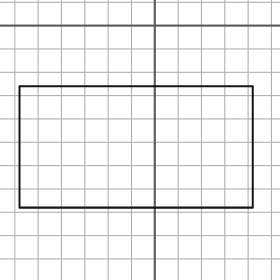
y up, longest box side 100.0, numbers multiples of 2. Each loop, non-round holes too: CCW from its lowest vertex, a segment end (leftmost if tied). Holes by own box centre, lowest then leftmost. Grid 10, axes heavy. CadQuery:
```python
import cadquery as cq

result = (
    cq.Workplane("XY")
    .moveTo(-58.0, -78.0)
    .lineTo(42.0, -78.0)
    .lineTo(42.0, -26.0)
    .lineTo(-58.0, -26.0)
    .close()
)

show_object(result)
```